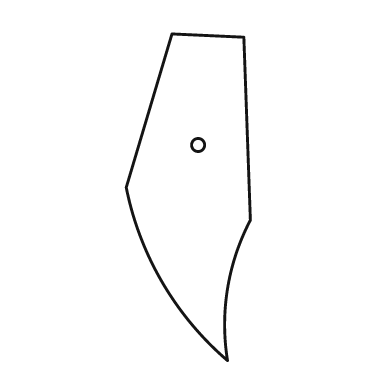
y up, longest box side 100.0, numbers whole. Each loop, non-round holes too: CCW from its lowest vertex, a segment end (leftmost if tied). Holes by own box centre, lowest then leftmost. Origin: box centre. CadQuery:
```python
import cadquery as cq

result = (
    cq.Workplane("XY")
    .moveTo(12.0, -50.0)
    .threePointArc((12.0, -28.0), (19.0, -7.0))
    .lineTo(17.0, 49.0)
    .lineTo(-5.0, 50.0)
    .lineTo(-19.0, 3.0)
    .threePointArc((-8.0, -26.0), (12.0, -50.0))
    .close()
    .moveTo(3.0, 16.0)
    .circle(2.0)
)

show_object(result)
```